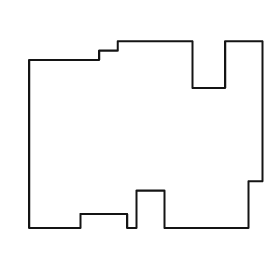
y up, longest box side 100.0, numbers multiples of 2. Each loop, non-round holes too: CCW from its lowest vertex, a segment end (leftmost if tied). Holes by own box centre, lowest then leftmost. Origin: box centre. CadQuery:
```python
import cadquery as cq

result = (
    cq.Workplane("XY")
    .moveTo(-50.0, -40.0)
    .lineTo(-28.0, -40.0)
    .lineTo(-28.0, -34.0)
    .lineTo(-8.0, -34.0)
    .lineTo(-8.0, -40.0)
    .lineTo(-4.0, -40.0)
    .lineTo(-4.0, -24.0)
    .lineTo(8.0, -24.0)
    .lineTo(8.0, -40.0)
    .lineTo(44.0, -40.0)
    .lineTo(44.0, -20.0)
    .lineTo(50.0, -20.0)
    .lineTo(50.0, 40.0)
    .lineTo(34.0, 40.0)
    .lineTo(34.0, 20.0)
    .lineTo(20.0, 20.0)
    .lineTo(20.0, 40.0)
    .lineTo(-12.0, 40.0)
    .lineTo(-12.0, 36.0)
    .lineTo(-20.0, 36.0)
    .lineTo(-20.0, 32.0)
    .lineTo(-50.0, 32.0)
    .close()
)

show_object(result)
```